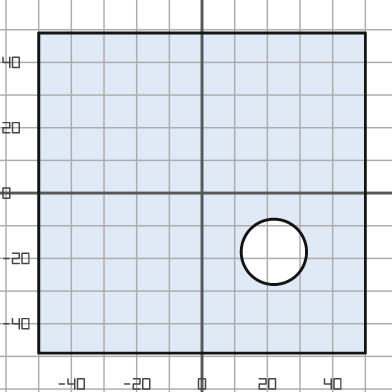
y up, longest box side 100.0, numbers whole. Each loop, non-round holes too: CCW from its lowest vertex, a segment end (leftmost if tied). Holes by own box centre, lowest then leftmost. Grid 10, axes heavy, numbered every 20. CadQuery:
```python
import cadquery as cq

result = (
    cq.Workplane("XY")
    .moveTo(-50.0, -49.0)
    .lineTo(50.0, -49.0)
    .lineTo(50.0, 49.0)
    .lineTo(-50.0, 49.0)
    .close()
    .moveTo(22.0, -18.0)
    .circle(10.0)
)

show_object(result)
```